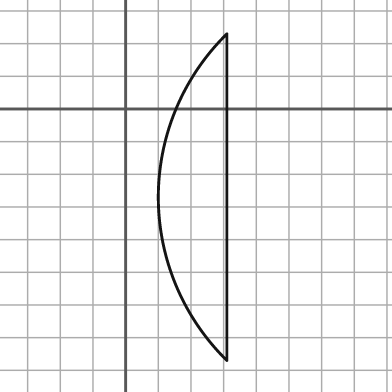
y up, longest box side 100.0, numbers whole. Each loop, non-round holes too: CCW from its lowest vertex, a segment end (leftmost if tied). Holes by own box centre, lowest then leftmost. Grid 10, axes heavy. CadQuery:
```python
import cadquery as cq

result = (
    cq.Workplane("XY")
    .moveTo(31.0, -77.0)
    .lineTo(31.0, 23.0)
    .threePointArc((10.0, -27.0), (31.0, -77.0))
    .close()
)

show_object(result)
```